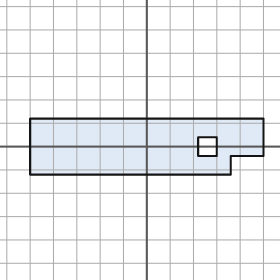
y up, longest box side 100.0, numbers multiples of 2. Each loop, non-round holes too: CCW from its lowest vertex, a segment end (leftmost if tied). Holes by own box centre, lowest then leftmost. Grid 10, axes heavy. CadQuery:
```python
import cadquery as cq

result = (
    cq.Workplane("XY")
    .moveTo(-50.0, -12.0)
    .lineTo(36.0, -12.0)
    .lineTo(36.0, -4.0)
    .lineTo(50.0, -4.0)
    .lineTo(50.0, 12.0)
    .lineTo(-50.0, 12.0)
    .close()
    .moveTo(22.0, -4.0)
    .lineTo(30.0, -4.0)
    .lineTo(30.0, 4.0)
    .lineTo(22.0, 4.0)
    .close()
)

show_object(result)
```